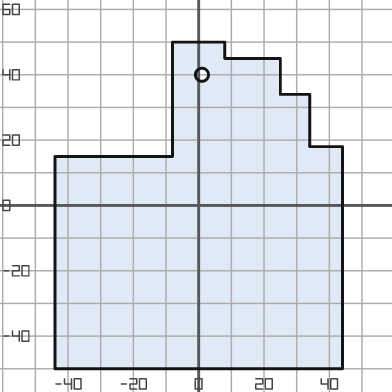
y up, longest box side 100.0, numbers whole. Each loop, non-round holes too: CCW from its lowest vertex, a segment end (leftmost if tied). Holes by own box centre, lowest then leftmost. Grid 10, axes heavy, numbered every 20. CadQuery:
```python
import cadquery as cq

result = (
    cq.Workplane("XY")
    .moveTo(-44.0, -50.0)
    .lineTo(44.0, -50.0)
    .lineTo(44.0, 18.0)
    .lineTo(34.0, 18.0)
    .lineTo(34.0, 34.0)
    .lineTo(25.0, 34.0)
    .lineTo(25.0, 45.0)
    .lineTo(8.0, 45.0)
    .lineTo(8.0, 50.0)
    .lineTo(-8.0, 50.0)
    .lineTo(-8.0, 15.0)
    .lineTo(-44.0, 15.0)
    .close()
    .moveTo(1.0, 40.0)
    .circle(2.0)
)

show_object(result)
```